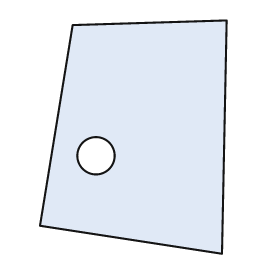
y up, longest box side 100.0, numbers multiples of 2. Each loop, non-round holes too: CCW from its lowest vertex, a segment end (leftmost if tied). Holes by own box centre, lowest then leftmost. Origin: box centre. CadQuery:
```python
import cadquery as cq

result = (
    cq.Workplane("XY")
    .moveTo(38.0, -50.0)
    .lineTo(40.0, 50.0)
    .lineTo(-26.0, 48.0)
    .lineTo(-40.0, -38.0)
    .close()
    .moveTo(-16.0, -8.0)
    .circle(8.0)
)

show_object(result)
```